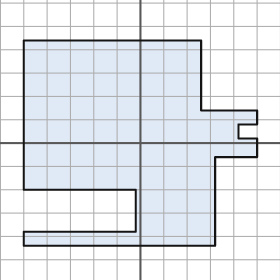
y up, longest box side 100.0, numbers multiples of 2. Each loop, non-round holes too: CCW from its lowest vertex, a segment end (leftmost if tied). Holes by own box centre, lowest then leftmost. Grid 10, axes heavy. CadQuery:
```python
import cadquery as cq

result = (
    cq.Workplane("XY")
    .moveTo(-50.0, -44.0)
    .lineTo(32.0, -44.0)
    .lineTo(32.0, -6.0)
    .lineTo(50.0, -6.0)
    .lineTo(50.0, 2.0)
    .lineTo(42.0, 2.0)
    .lineTo(42.0, 8.0)
    .lineTo(50.0, 8.0)
    .lineTo(50.0, 14.0)
    .lineTo(26.0, 14.0)
    .lineTo(26.0, 44.0)
    .lineTo(-50.0, 44.0)
    .lineTo(-50.0, -20.0)
    .lineTo(-2.0, -20.0)
    .lineTo(-2.0, -38.0)
    .lineTo(-50.0, -38.0)
    .close()
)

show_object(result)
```